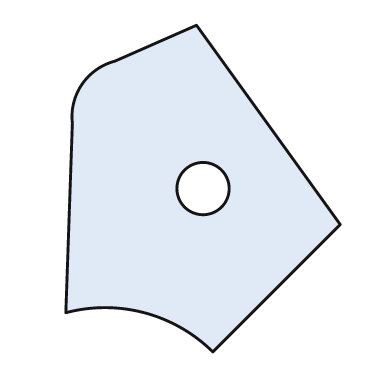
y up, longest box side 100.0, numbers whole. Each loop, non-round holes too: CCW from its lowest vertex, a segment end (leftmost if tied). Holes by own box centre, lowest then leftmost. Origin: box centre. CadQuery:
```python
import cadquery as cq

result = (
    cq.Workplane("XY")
    .moveTo(3.0, -50.0)
    .lineTo(42.0, -11.0)
    .lineTo(-2.0, 50.0)
    .lineTo(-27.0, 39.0)
    .threePointArc((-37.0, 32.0), (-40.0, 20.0))
    .lineTo(-42.0, -38.0)
    .threePointArc((-18.0, -38.0), (3.0, -50.0))
    .close()
    .moveTo(0.0, 0.0)
    .circle(8.0)
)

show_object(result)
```